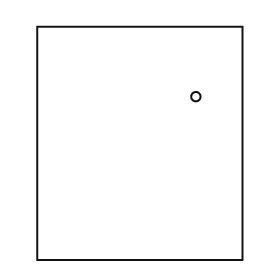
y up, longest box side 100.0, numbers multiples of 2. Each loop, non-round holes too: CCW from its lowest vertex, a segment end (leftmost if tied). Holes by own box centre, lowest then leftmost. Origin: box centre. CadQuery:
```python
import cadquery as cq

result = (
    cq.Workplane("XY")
    .moveTo(-44.0, -50.0)
    .lineTo(44.0, -50.0)
    .lineTo(44.0, 50.0)
    .lineTo(-44.0, 50.0)
    .close()
    .moveTo(24.0, 20.0)
    .circle(2.0)
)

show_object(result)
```